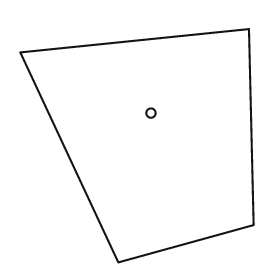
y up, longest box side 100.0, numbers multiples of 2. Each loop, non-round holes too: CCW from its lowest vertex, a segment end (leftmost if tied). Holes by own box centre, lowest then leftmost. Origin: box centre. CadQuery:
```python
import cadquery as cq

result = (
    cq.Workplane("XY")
    .moveTo(-8.0, -50.0)
    .lineTo(50.0, -34.0)
    .lineTo(48.0, 50.0)
    .lineTo(-50.0, 40.0)
    .close()
    .moveTo(6.0, 14.0)
    .circle(2.0)
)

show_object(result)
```